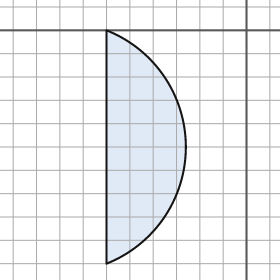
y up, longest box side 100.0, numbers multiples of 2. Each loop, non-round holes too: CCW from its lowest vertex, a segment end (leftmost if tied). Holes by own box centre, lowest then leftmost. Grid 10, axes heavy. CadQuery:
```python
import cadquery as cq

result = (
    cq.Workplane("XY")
    .moveTo(-60.0, -100.0)
    .threePointArc((-26.0, -50.0), (-60.0, 0.0))
    .close()
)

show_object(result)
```